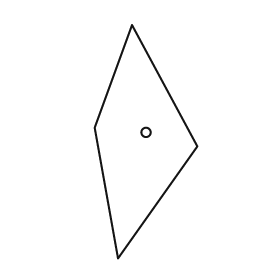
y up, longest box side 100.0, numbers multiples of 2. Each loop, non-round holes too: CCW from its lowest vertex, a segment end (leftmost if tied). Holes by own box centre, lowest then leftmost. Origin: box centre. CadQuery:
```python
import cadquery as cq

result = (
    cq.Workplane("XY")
    .moveTo(-12.0, -50.0)
    .lineTo(22.0, -2.0)
    .lineTo(-6.0, 50.0)
    .lineTo(-22.0, 6.0)
    .close()
    .moveTo(0.0, 4.0)
    .circle(2.0)
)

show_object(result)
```